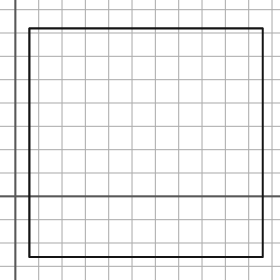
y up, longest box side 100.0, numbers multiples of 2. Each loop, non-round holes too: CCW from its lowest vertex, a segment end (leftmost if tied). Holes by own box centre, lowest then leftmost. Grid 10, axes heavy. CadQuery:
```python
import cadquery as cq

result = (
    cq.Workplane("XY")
    .moveTo(6.0, -26.0)
    .lineTo(106.0, -26.0)
    .lineTo(106.0, 72.0)
    .lineTo(6.0, 72.0)
    .close()
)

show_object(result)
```